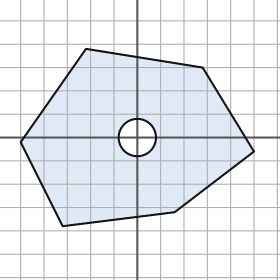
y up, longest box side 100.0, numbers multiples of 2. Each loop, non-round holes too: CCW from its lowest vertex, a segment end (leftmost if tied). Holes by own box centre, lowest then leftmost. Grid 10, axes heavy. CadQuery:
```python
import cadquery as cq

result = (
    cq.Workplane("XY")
    .moveTo(-32.0, -38.0)
    .lineTo(16.0, -32.0)
    .lineTo(50.0, -6.0)
    .lineTo(28.0, 30.0)
    .lineTo(-22.0, 38.0)
    .lineTo(-50.0, -2.0)
    .close()
    .moveTo(0.0, 0.0)
    .circle(8.0)
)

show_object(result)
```